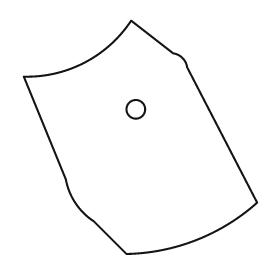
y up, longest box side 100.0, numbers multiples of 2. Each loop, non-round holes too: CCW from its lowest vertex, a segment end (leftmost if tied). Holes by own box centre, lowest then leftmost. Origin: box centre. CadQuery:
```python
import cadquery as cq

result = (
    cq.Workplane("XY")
    .moveTo(-6.0, -50.0)
    .threePointArc((24.0, -44.0), (50.0, -28.0))
    .lineTo(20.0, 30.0)
    .threePointArc((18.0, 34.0), (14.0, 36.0))
    .lineTo(-4.0, 50.0)
    .threePointArc((-24.0, 32.0), (-50.0, 26.0))
    .lineTo(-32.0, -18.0)
    .threePointArc((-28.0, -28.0), (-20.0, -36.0))
    .close()
    .moveTo(-2.0, 12.0)
    .circle(4.0)
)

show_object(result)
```